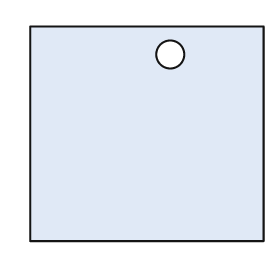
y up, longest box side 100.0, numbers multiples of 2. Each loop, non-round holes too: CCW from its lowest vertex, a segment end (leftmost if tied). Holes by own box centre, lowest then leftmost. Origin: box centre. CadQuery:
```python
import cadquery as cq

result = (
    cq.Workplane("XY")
    .moveTo(-50.0, -46.0)
    .lineTo(50.0, -46.0)
    .lineTo(50.0, 46.0)
    .lineTo(-50.0, 46.0)
    .close()
    .moveTo(10.0, 34.0)
    .circle(6.0)
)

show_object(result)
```